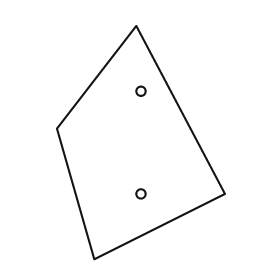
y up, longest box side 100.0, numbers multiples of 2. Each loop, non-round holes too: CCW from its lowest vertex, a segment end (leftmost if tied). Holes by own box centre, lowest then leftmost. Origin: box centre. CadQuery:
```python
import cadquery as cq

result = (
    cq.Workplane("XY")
    .moveTo(-20.0, -50.0)
    .lineTo(36.0, -22.0)
    .lineTo(-2.0, 50.0)
    .lineTo(-36.0, 6.0)
    .close()
    .moveTo(0.0, -22.0)
    .circle(2.0)
    .moveTo(0.0, 22.0)
    .circle(2.0)
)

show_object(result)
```